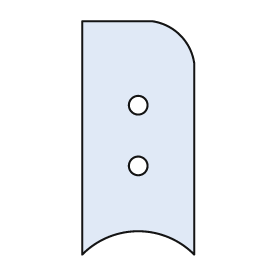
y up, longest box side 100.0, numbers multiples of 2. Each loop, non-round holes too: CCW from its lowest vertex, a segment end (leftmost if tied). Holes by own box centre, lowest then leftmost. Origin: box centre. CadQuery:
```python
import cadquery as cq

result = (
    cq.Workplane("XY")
    .moveTo(-24.0, -50.0)
    .threePointArc((0.0, -40.0), (24.0, -50.0))
    .lineTo(24.0, 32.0)
    .threePointArc((18.0, 44.0), (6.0, 50.0))
    .lineTo(-24.0, 50.0)
    .close()
    .moveTo(0.0, -12.0)
    .circle(4.0)
    .moveTo(0.0, 14.0)
    .circle(4.0)
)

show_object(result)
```